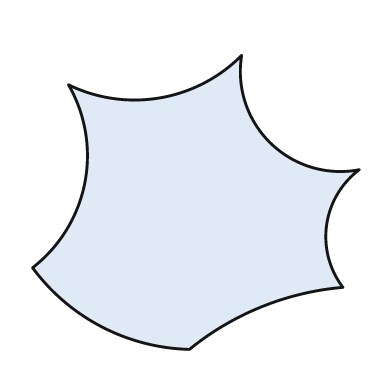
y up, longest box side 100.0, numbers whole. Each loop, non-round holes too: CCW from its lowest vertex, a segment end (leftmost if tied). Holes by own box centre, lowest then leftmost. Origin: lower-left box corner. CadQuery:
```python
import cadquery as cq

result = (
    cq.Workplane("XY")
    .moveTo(48.0, 0.0)
    .threePointArc((70.0, 13.0), (95.0, 19.0))
    .threePointArc((90.0, 38.0), (100.0, 55.0))
    .threePointArc((73.0, 63.0), (64.0, 90.0))
    .threePointArc((39.0, 77.0), (11.0, 81.0))
    .threePointArc((16.0, 51.0), (0.0, 25.0))
    .threePointArc((21.0, 7.0), (48.0, 0.0))
    .close()
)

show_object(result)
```